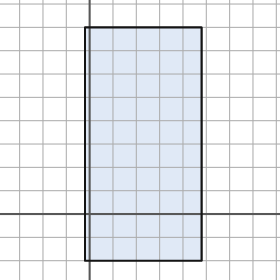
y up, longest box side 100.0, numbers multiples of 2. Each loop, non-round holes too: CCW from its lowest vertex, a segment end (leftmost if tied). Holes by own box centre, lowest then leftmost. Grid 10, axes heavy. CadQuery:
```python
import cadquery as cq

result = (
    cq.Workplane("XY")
    .moveTo(-2.0, -20.0)
    .lineTo(48.0, -20.0)
    .lineTo(48.0, 80.0)
    .lineTo(-2.0, 80.0)
    .close()
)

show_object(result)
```